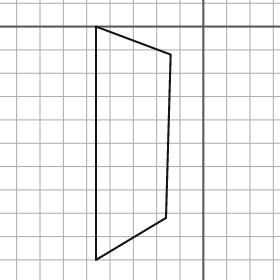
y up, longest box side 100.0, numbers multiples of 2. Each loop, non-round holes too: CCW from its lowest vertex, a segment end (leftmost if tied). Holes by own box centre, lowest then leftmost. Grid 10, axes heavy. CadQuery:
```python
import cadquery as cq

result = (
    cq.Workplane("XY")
    .moveTo(-46.0, -100.0)
    .lineTo(-16.0, -82.0)
    .lineTo(-14.0, -12.0)
    .lineTo(-46.0, 0.0)
    .close()
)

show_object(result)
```